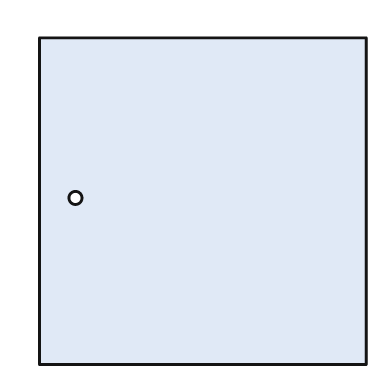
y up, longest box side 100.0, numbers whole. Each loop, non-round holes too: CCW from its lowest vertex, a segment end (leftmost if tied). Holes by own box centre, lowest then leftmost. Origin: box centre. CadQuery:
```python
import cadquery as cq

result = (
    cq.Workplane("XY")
    .moveTo(-50.0, -50.0)
    .lineTo(50.0, -50.0)
    .lineTo(50.0, 50.0)
    .lineTo(-50.0, 50.0)
    .close()
    .moveTo(-39.0, 1.0)
    .circle(2.0)
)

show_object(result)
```